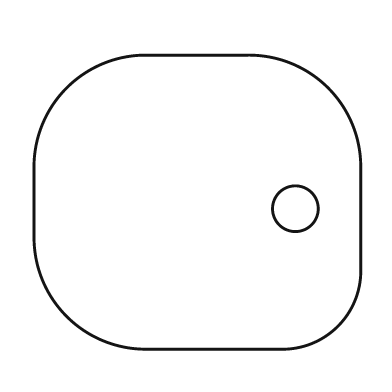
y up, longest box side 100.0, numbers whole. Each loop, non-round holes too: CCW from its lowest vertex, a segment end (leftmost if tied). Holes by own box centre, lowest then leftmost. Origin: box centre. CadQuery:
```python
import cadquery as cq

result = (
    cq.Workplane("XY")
    .moveTo(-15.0, -45.0)
    .lineTo(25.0, -45.0)
    .threePointArc((43.0, -38.0), (50.0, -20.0))
    .lineTo(50.0, 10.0)
    .threePointArc((40.0, 35.0), (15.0, 45.0))
    .lineTo(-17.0, 45.0)
    .threePointArc((-40.0, 35.0), (-50.0, 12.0))
    .lineTo(-50.0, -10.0)
    .threePointArc((-40.0, -35.0), (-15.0, -45.0))
    .close()
    .moveTo(30.0, -2.0)
    .circle(7.0)
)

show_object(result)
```